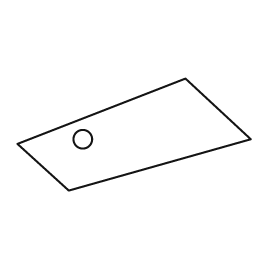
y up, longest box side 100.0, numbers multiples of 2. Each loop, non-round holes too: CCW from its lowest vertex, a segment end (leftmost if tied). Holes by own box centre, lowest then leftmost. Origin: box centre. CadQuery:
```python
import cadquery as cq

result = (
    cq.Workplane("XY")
    .moveTo(-28.0, -24.0)
    .lineTo(50.0, -2.0)
    .lineTo(22.0, 24.0)
    .lineTo(-50.0, -4.0)
    .close()
    .moveTo(-22.0, -2.0)
    .circle(4.0)
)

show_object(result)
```